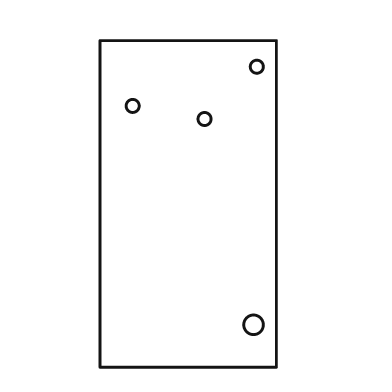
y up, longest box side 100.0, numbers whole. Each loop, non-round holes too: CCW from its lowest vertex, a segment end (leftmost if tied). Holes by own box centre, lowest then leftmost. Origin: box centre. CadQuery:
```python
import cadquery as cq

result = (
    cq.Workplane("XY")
    .moveTo(-27.0, -50.0)
    .lineTo(27.0, -50.0)
    .lineTo(27.0, 50.0)
    .lineTo(-27.0, 50.0)
    .close()
    .moveTo(20.0, -37.0)
    .circle(3.0)
    .moveTo(5.0, 26.0)
    .circle(2.0)
    .moveTo(-17.0, 30.0)
    .circle(2.0)
    .moveTo(21.0, 42.0)
    .circle(2.0)
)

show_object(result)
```